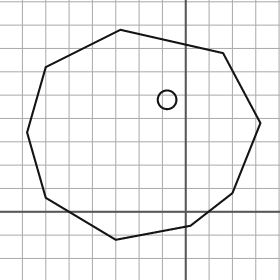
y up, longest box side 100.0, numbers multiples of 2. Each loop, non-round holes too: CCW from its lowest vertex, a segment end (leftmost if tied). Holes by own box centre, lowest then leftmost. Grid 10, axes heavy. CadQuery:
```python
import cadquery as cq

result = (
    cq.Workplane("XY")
    .moveTo(-30.0, -12.0)
    .lineTo(2.0, -6.0)
    .lineTo(20.0, 8.0)
    .lineTo(32.0, 38.0)
    .lineTo(16.0, 68.0)
    .lineTo(-28.0, 78.0)
    .lineTo(-60.0, 62.0)
    .lineTo(-68.0, 34.0)
    .lineTo(-60.0, 6.0)
    .close()
    .moveTo(-8.0, 48.0)
    .circle(4.0)
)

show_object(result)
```